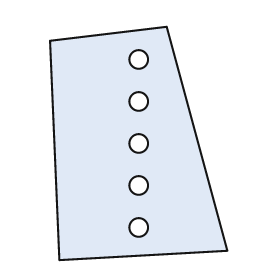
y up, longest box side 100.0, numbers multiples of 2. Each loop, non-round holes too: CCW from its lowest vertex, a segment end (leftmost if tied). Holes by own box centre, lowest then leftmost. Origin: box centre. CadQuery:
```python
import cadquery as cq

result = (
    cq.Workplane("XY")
    .moveTo(-34.0, -50.0)
    .lineTo(38.0, -46.0)
    .lineTo(12.0, 50.0)
    .lineTo(-38.0, 44.0)
    .close()
    .moveTo(0.0, -36.0)
    .circle(4.0)
    .moveTo(0.0, -18.0)
    .circle(4.0)
    .moveTo(0.0, 0.0)
    .circle(4.0)
    .moveTo(0.0, 18.0)
    .circle(4.0)
    .moveTo(0.0, 36.0)
    .circle(4.0)
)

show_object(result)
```